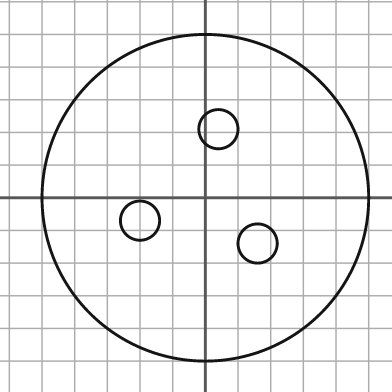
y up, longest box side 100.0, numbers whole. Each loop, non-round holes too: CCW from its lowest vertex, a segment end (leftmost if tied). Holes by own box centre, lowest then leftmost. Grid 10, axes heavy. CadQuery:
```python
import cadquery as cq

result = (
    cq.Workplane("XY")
    .moveTo(0.0, 0.0)
    .circle(50.0)
    .moveTo(16.0, -14.0)
    .circle(6.0)
    .moveTo(-20.0, -7.0)
    .circle(6.0)
    .moveTo(4.0, 21.0)
    .circle(6.0)
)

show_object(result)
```